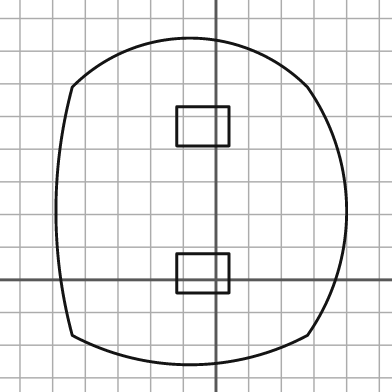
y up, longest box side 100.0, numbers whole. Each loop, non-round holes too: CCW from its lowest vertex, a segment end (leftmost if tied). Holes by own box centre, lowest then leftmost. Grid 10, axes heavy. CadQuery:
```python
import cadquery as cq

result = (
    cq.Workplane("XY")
    .moveTo(-44.0, -17.0)
    .threePointArc((-8.0, -26.0), (28.0, -17.0))
    .threePointArc((40.0, 21.0), (28.0, 59.0))
    .threePointArc((-8.0, 74.0), (-44.0, 59.0))
    .threePointArc((-49.0, 21.0), (-44.0, -17.0))
    .close()
    .moveTo(-12.0, -4.0)
    .lineTo(4.0, -4.0)
    .lineTo(4.0, 8.0)
    .lineTo(-12.0, 8.0)
    .close()
    .moveTo(-12.0, 41.0)
    .lineTo(4.0, 41.0)
    .lineTo(4.0, 53.0)
    .lineTo(-12.0, 53.0)
    .close()
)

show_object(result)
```